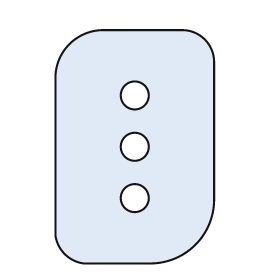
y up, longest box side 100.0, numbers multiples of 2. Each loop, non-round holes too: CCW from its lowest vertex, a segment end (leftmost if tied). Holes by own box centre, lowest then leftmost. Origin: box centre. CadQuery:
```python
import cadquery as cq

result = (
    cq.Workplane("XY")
    .moveTo(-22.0, -50.0)
    .lineTo(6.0, -50.0)
    .threePointArc((26.0, -42.0), (34.0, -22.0))
    .lineTo(34.0, 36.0)
    .threePointArc((30.0, 46.0), (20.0, 50.0))
    .lineTo(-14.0, 50.0)
    .threePointArc((-28.0, 44.0), (-34.0, 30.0))
    .lineTo(-34.0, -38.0)
    .threePointArc((-30.0, -46.0), (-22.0, -50.0))
    .close()
    .moveTo(0.0, -22.0)
    .circle(6.0)
    .moveTo(0.0, 0.0)
    .circle(6.0)
    .moveTo(0.0, 22.0)
    .circle(6.0)
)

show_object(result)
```